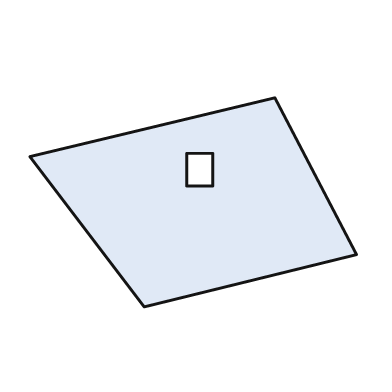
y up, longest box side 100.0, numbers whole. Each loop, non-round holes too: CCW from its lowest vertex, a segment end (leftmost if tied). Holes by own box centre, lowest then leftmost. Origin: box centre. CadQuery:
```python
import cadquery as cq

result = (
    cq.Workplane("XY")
    .moveTo(-15.0, -32.0)
    .lineTo(50.0, -16.0)
    .lineTo(25.0, 32.0)
    .lineTo(-50.0, 14.0)
    .close()
    .moveTo(-2.0, 5.0)
    .lineTo(6.0, 5.0)
    .lineTo(6.0, 15.0)
    .lineTo(-2.0, 15.0)
    .close()
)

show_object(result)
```